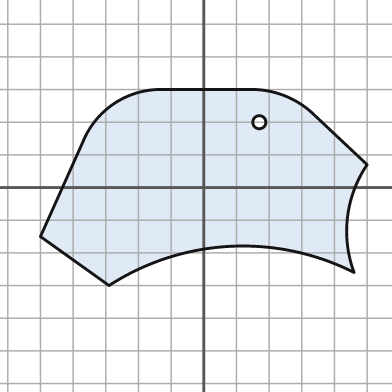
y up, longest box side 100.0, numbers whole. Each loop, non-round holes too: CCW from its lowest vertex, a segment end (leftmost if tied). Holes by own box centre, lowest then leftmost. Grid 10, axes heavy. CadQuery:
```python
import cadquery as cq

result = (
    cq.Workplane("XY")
    .moveTo(-29.0, -30.0)
    .threePointArc((8.0, -18.0), (46.0, -26.0))
    .threePointArc((44.0, -9.0), (50.0, 7.0))
    .lineTo(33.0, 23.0)
    .threePointArc((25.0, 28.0), (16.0, 30.0))
    .lineTo(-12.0, 30.0)
    .threePointArc((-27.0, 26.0), (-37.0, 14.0))
    .lineTo(-50.0, -15.0)
    .close()
    .moveTo(17.0, 20.0)
    .circle(2.0)
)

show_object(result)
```